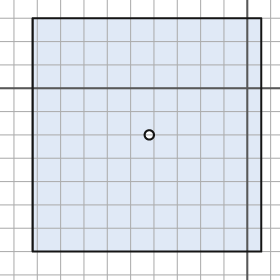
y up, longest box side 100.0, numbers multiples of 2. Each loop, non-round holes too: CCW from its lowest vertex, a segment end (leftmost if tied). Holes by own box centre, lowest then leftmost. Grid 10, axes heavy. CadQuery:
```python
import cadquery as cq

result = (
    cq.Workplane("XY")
    .moveTo(-92.0, -70.0)
    .lineTo(6.0, -70.0)
    .lineTo(6.0, 30.0)
    .lineTo(-92.0, 30.0)
    .close()
    .moveTo(-42.0, -20.0)
    .circle(2.0)
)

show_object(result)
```